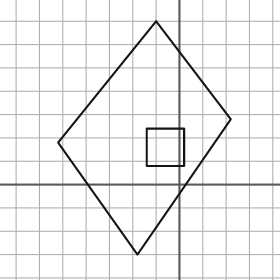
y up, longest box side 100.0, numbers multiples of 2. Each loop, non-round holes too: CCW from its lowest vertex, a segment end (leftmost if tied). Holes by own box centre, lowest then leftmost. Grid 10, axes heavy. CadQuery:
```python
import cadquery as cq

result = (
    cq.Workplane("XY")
    .moveTo(-18.0, -30.0)
    .lineTo(22.0, 28.0)
    .lineTo(-10.0, 70.0)
    .lineTo(-52.0, 18.0)
    .close()
    .moveTo(-14.0, 8.0)
    .lineTo(2.0, 8.0)
    .lineTo(2.0, 24.0)
    .lineTo(-14.0, 24.0)
    .close()
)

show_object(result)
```